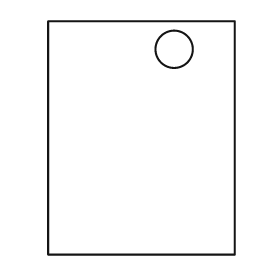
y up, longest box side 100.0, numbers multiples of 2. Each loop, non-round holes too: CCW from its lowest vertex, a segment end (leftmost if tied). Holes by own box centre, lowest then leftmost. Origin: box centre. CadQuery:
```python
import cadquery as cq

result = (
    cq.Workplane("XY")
    .moveTo(-40.0, -50.0)
    .lineTo(40.0, -50.0)
    .lineTo(40.0, 50.0)
    .lineTo(-40.0, 50.0)
    .close()
    .moveTo(14.0, 38.0)
    .circle(8.0)
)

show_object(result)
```